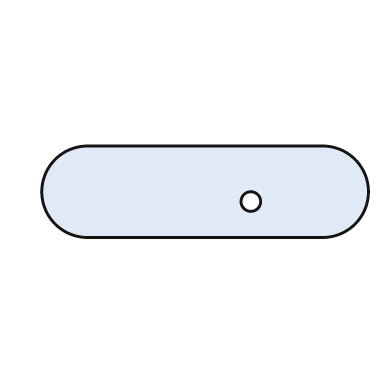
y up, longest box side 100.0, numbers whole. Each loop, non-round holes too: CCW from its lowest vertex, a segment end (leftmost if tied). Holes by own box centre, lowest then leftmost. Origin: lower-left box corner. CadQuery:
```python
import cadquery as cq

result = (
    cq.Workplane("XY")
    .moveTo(14.0, 0.0)
    .lineTo(86.0, 0.0)
    .threePointArc((100.0, 14.0), (86.0, 28.0))
    .lineTo(14.0, 28.0)
    .threePointArc((0.0, 14.0), (14.0, 0.0))
    .close()
    .moveTo(64.0, 11.0)
    .circle(3.0)
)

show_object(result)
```